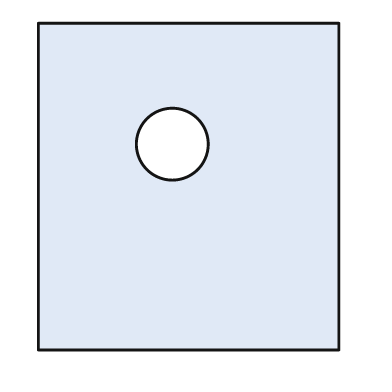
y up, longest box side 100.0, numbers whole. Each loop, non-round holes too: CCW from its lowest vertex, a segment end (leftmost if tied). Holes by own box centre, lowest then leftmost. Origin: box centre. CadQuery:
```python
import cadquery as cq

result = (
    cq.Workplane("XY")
    .moveTo(-46.0, -50.0)
    .lineTo(46.0, -50.0)
    .lineTo(46.0, 50.0)
    .lineTo(-46.0, 50.0)
    .close()
    .moveTo(-5.0, 13.0)
    .circle(11.0)
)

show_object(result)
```